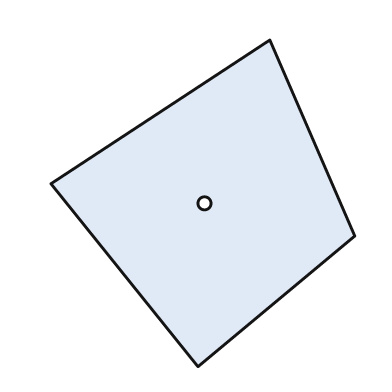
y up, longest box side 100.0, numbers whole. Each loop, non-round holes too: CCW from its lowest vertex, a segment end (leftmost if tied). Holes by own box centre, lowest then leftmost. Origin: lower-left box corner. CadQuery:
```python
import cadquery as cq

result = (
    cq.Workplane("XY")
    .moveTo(45.0, 0.0)
    .lineTo(93.0, 40.0)
    .lineTo(67.0, 100.0)
    .lineTo(0.0, 56.0)
    .close()
    .moveTo(47.0, 50.0)
    .circle(2.0)
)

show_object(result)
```